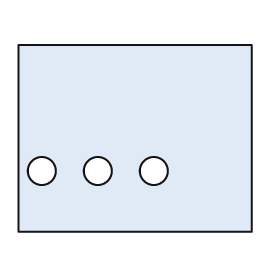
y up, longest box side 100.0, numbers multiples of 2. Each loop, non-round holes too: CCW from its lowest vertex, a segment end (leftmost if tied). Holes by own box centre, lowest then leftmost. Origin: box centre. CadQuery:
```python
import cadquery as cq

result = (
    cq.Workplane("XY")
    .moveTo(-50.0, -40.0)
    .lineTo(50.0, -40.0)
    .lineTo(50.0, 40.0)
    .lineTo(-50.0, 40.0)
    .close()
    .moveTo(-40.0, -14.0)
    .circle(6.0)
    .moveTo(-16.0, -14.0)
    .circle(6.0)
    .moveTo(8.0, -14.0)
    .circle(6.0)
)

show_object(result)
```